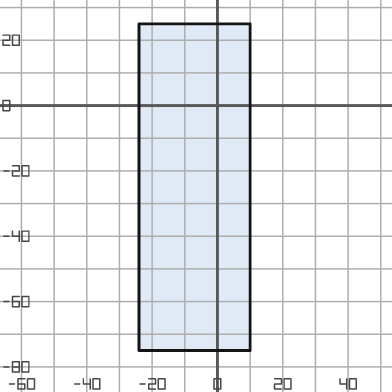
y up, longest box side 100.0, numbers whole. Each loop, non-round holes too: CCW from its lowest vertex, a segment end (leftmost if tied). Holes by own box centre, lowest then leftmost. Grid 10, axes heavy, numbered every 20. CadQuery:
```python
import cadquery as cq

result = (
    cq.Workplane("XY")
    .moveTo(-24.0, -75.0)
    .lineTo(10.0, -75.0)
    .lineTo(10.0, 25.0)
    .lineTo(-24.0, 25.0)
    .close()
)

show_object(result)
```